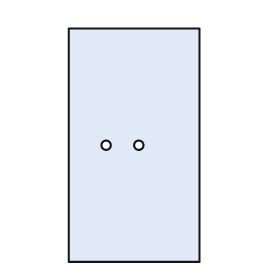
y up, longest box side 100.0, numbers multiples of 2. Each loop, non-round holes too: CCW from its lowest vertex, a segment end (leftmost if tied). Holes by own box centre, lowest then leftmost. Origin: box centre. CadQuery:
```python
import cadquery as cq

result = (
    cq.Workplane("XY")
    .moveTo(-28.0, -50.0)
    .lineTo(28.0, -50.0)
    .lineTo(28.0, 50.0)
    .lineTo(-28.0, 50.0)
    .close()
    .moveTo(-12.0, 0.0)
    .circle(2.0)
    .moveTo(2.0, 0.0)
    .circle(2.0)
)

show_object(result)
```